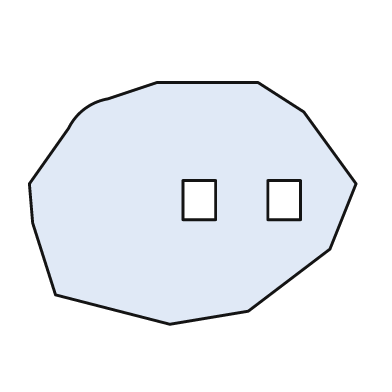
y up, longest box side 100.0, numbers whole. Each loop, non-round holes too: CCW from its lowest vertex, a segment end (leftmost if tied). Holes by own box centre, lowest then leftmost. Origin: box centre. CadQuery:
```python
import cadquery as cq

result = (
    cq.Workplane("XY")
    .moveTo(-7.0, -37.0)
    .lineTo(17.0, -33.0)
    .lineTo(42.0, -14.0)
    .lineTo(50.0, 6.0)
    .lineTo(34.0, 28.0)
    .lineTo(20.0, 37.0)
    .lineTo(-11.0, 37.0)
    .lineTo(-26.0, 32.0)
    .threePointArc((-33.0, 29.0), (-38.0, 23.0))
    .lineTo(-50.0, 6.0)
    .lineTo(-49.0, -6.0)
    .lineTo(-42.0, -28.0)
    .close()
    .moveTo(-3.0, -5.0)
    .lineTo(7.0, -5.0)
    .lineTo(7.0, 7.0)
    .lineTo(-3.0, 7.0)
    .close()
    .moveTo(23.0, -5.0)
    .lineTo(33.0, -5.0)
    .lineTo(33.0, 7.0)
    .lineTo(23.0, 7.0)
    .close()
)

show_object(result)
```